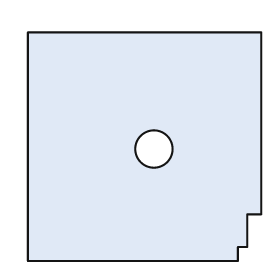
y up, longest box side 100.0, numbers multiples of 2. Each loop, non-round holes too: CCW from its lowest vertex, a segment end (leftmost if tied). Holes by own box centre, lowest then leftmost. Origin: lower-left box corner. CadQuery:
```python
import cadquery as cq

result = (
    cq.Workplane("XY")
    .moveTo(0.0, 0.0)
    .lineTo(90.0, 0.0)
    .lineTo(90.0, 6.0)
    .lineTo(94.0, 6.0)
    .lineTo(94.0, 20.0)
    .lineTo(100.0, 20.0)
    .lineTo(100.0, 98.0)
    .lineTo(0.0, 98.0)
    .close()
    .moveTo(54.0, 48.0)
    .circle(8.0)
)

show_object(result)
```